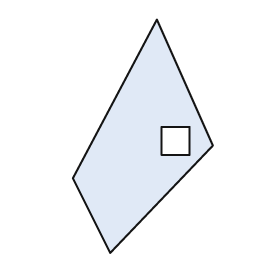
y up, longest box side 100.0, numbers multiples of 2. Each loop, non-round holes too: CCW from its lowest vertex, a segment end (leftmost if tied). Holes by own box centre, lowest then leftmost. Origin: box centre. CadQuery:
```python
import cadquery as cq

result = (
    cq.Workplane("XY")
    .moveTo(-14.0, -50.0)
    .lineTo(30.0, -4.0)
    .lineTo(6.0, 50.0)
    .lineTo(-30.0, -18.0)
    .close()
    .moveTo(8.0, -8.0)
    .lineTo(20.0, -8.0)
    .lineTo(20.0, 4.0)
    .lineTo(8.0, 4.0)
    .close()
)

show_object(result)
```